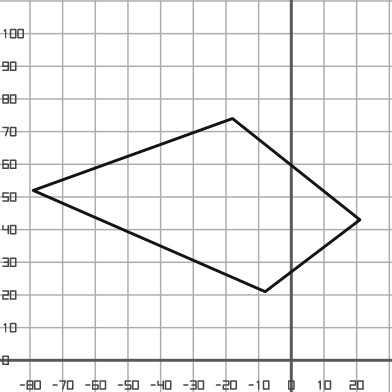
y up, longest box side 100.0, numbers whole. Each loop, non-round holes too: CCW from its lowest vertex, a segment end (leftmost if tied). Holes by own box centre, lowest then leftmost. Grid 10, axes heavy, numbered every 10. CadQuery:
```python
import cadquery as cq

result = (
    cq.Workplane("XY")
    .moveTo(-8.0, 21.0)
    .lineTo(21.0, 43.0)
    .lineTo(-18.0, 74.0)
    .lineTo(-79.0, 52.0)
    .close()
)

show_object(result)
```